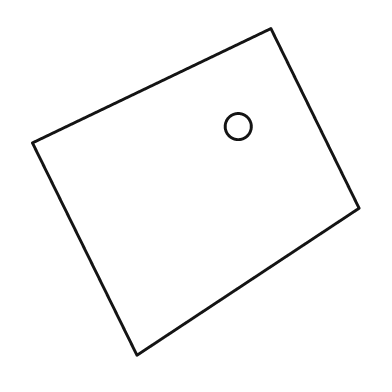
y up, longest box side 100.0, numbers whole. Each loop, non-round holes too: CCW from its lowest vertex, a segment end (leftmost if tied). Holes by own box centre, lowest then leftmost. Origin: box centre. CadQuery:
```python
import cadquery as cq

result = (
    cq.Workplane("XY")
    .moveTo(-18.0, -50.0)
    .lineTo(50.0, -5.0)
    .lineTo(23.0, 50.0)
    .lineTo(-50.0, 15.0)
    .close()
    .moveTo(13.0, 20.0)
    .circle(4.0)
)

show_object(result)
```